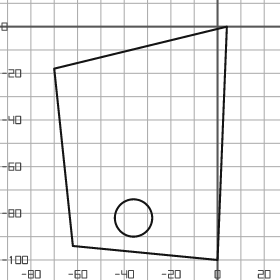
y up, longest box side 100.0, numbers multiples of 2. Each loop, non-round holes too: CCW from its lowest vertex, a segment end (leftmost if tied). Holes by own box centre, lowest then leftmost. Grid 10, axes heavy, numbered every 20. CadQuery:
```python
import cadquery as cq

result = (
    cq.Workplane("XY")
    .moveTo(0.0, -100.0)
    .lineTo(4.0, 0.0)
    .lineTo(-70.0, -18.0)
    .lineTo(-62.0, -94.0)
    .close()
    .moveTo(-36.0, -82.0)
    .circle(8.0)
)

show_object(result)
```